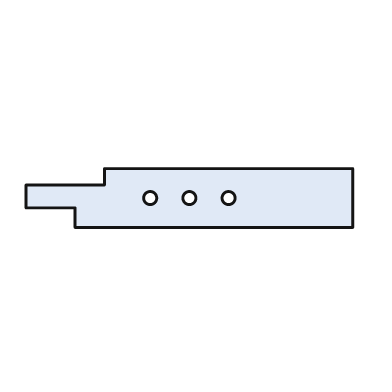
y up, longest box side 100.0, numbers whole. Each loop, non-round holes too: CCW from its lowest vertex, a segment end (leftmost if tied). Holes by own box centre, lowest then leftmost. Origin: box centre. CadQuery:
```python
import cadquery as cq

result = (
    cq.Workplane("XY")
    .moveTo(-35.0, -9.0)
    .lineTo(50.0, -9.0)
    .lineTo(50.0, 9.0)
    .lineTo(-26.0, 9.0)
    .lineTo(-26.0, 4.0)
    .lineTo(-50.0, 4.0)
    .lineTo(-50.0, -3.0)
    .lineTo(-35.0, -3.0)
    .close()
    .moveTo(-12.0, 0.0)
    .circle(2.0)
    .moveTo(0.0, 0.0)
    .circle(2.0)
    .moveTo(12.0, 0.0)
    .circle(2.0)
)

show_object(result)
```